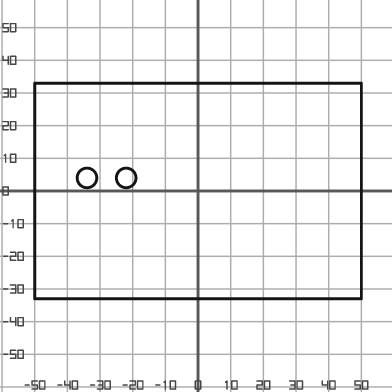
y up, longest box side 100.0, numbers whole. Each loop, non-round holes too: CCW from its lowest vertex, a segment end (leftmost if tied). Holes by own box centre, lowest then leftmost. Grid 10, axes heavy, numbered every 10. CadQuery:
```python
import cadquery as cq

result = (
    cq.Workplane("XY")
    .moveTo(-50.0, -33.0)
    .lineTo(50.0, -33.0)
    .lineTo(50.0, 33.0)
    .lineTo(-50.0, 33.0)
    .close()
    .moveTo(-34.0, 4.0)
    .circle(3.0)
    .moveTo(-22.0, 4.0)
    .circle(3.0)
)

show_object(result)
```